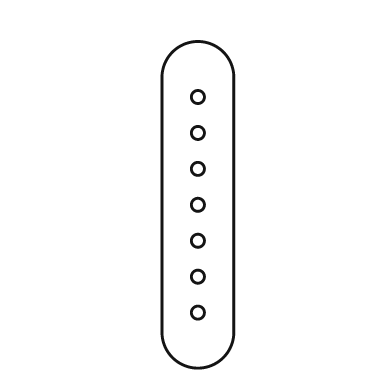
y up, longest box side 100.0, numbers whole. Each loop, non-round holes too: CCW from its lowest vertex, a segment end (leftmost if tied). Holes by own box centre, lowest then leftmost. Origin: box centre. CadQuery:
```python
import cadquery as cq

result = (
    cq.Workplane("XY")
    .moveTo(-11.0, -39.0)
    .threePointArc((0.0, -50.0), (11.0, -39.0))
    .lineTo(11.0, 39.0)
    .threePointArc((0.0, 50.0), (-11.0, 39.0))
    .close()
    .moveTo(0.0, -33.0)
    .circle(2.0)
    .moveTo(0.0, -22.0)
    .circle(2.0)
    .moveTo(0.0, -11.0)
    .circle(2.0)
    .moveTo(0.0, 0.0)
    .circle(2.0)
    .moveTo(0.0, 11.0)
    .circle(2.0)
    .moveTo(0.0, 22.0)
    .circle(2.0)
    .moveTo(0.0, 33.0)
    .circle(2.0)
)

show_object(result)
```